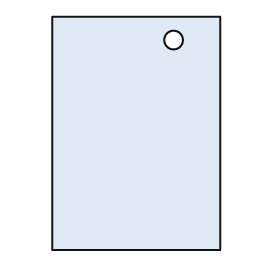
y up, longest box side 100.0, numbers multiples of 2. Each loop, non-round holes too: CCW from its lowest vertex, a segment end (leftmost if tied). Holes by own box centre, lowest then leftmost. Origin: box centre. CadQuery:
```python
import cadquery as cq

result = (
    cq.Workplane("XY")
    .moveTo(-36.0, -50.0)
    .lineTo(36.0, -50.0)
    .lineTo(36.0, 50.0)
    .lineTo(-36.0, 50.0)
    .close()
    .moveTo(16.0, 40.0)
    .circle(4.0)
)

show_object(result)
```